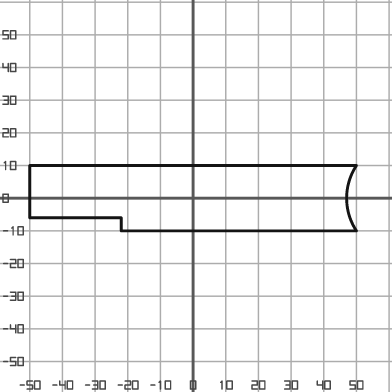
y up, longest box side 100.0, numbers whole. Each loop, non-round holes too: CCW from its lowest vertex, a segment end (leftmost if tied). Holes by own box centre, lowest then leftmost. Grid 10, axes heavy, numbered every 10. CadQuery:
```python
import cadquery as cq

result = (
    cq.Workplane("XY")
    .moveTo(-22.0, -10.0)
    .lineTo(50.0, -10.0)
    .threePointArc((47.0, 0.0), (50.0, 10.0))
    .lineTo(-50.0, 10.0)
    .lineTo(-50.0, -6.0)
    .lineTo(-22.0, -6.0)
    .close()
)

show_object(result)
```